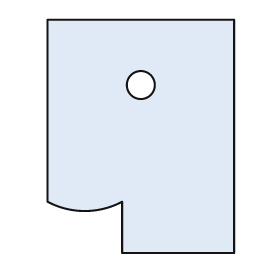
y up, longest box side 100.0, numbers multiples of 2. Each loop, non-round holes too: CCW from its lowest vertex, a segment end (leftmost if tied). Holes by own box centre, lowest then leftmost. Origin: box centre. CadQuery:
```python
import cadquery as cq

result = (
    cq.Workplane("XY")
    .moveTo(-8.0, -50.0)
    .lineTo(40.0, -50.0)
    .lineTo(40.0, 50.0)
    .lineTo(-40.0, 50.0)
    .lineTo(-40.0, -28.0)
    .threePointArc((-24.0, -32.0), (-8.0, -28.0))
    .close()
    .moveTo(0.0, 22.0)
    .circle(6.0)
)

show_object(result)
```